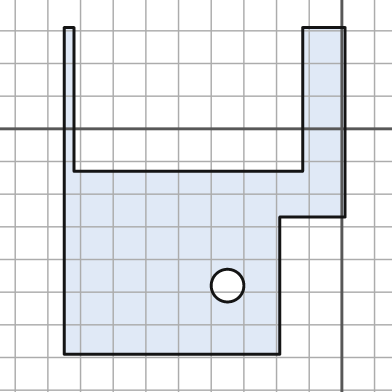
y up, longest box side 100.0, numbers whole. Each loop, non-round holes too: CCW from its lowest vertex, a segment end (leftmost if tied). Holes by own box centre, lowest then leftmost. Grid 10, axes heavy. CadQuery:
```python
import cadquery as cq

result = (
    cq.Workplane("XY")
    .moveTo(-85.0, -69.0)
    .lineTo(-19.0, -69.0)
    .lineTo(-19.0, -27.0)
    .lineTo(1.0, -27.0)
    .lineTo(1.0, 31.0)
    .lineTo(-12.0, 31.0)
    .lineTo(-12.0, -13.0)
    .lineTo(-82.0, -13.0)
    .lineTo(-82.0, 31.0)
    .lineTo(-85.0, 31.0)
    .close()
    .moveTo(-35.0, -48.0)
    .circle(5.0)
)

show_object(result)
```